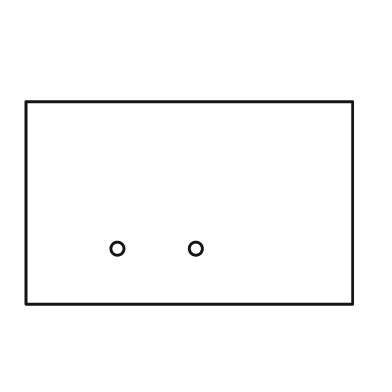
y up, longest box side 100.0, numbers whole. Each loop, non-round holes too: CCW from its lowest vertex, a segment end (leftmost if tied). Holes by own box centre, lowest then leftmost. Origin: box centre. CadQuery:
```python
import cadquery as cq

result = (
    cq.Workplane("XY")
    .moveTo(-50.0, -31.0)
    .lineTo(50.0, -31.0)
    .lineTo(50.0, 31.0)
    .lineTo(-50.0, 31.0)
    .close()
    .moveTo(-22.0, -14.0)
    .circle(2.0)
    .moveTo(2.0, -14.0)
    .circle(2.0)
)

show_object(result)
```